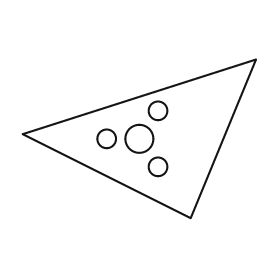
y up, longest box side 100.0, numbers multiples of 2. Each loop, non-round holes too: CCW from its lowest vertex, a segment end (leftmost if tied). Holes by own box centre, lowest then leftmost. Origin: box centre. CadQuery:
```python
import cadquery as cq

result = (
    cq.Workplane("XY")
    .moveTo(22.0, -34.0)
    .lineTo(50.0, 34.0)
    .lineTo(-50.0, 2.0)
    .close()
    .moveTo(8.0, -12.0)
    .circle(4.0)
    .moveTo(-14.0, 0.0)
    .circle(4.0)
    .moveTo(0.0, 0.0)
    .circle(6.0)
    .moveTo(8.0, 12.0)
    .circle(4.0)
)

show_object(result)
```